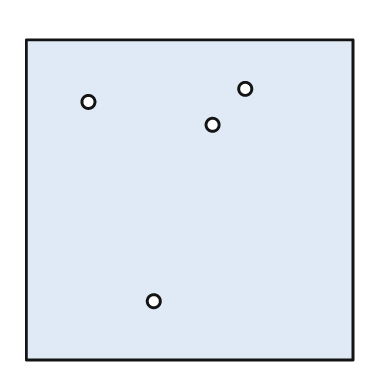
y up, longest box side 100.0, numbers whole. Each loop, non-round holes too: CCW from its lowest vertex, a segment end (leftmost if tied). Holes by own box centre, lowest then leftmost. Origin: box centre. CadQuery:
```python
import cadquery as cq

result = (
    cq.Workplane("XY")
    .moveTo(-50.0, -49.0)
    .lineTo(50.0, -49.0)
    .lineTo(50.0, 49.0)
    .lineTo(-50.0, 49.0)
    .close()
    .moveTo(-11.0, -31.0)
    .circle(2.0)
    .moveTo(7.0, 23.0)
    .circle(2.0)
    .moveTo(-31.0, 30.0)
    .circle(2.0)
    .moveTo(17.0, 34.0)
    .circle(2.0)
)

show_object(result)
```